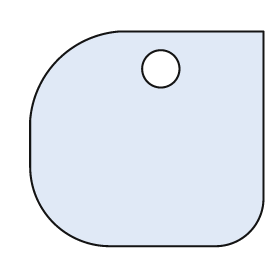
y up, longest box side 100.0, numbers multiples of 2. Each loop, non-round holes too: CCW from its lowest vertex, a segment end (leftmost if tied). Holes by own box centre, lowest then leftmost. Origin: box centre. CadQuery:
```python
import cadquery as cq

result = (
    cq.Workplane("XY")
    .moveTo(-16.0, -46.0)
    .lineTo(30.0, -46.0)
    .threePointArc((44.0, -40.0), (50.0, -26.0))
    .lineTo(50.0, 46.0)
    .lineTo(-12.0, 46.0)
    .threePointArc((-38.0, 34.0), (-50.0, 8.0))
    .lineTo(-50.0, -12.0)
    .threePointArc((-40.0, -36.0), (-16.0, -46.0))
    .close()
    .moveTo(6.0, 30.0)
    .circle(8.0)
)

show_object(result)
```